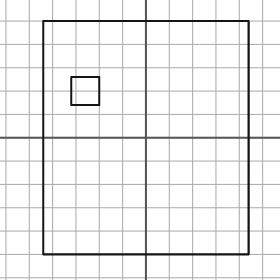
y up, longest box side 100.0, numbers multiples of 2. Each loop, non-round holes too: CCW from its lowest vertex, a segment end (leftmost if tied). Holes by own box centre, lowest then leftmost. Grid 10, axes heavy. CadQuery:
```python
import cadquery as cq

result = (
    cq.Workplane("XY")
    .moveTo(-44.0, -50.0)
    .lineTo(44.0, -50.0)
    .lineTo(44.0, 50.0)
    .lineTo(-44.0, 50.0)
    .close()
    .moveTo(-32.0, 14.0)
    .lineTo(-20.0, 14.0)
    .lineTo(-20.0, 26.0)
    .lineTo(-32.0, 26.0)
    .close()
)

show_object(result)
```